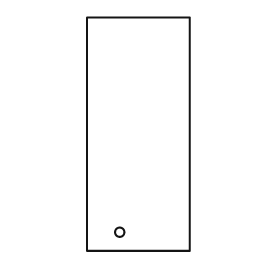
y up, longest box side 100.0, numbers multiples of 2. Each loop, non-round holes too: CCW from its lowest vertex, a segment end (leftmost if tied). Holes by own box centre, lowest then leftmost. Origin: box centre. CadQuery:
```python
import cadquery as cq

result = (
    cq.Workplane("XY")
    .moveTo(-22.0, -50.0)
    .lineTo(22.0, -50.0)
    .lineTo(22.0, 50.0)
    .lineTo(-22.0, 50.0)
    .close()
    .moveTo(-8.0, -42.0)
    .circle(2.0)
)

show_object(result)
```